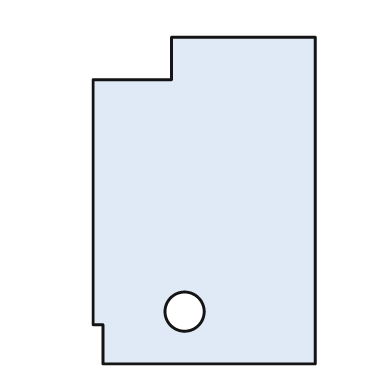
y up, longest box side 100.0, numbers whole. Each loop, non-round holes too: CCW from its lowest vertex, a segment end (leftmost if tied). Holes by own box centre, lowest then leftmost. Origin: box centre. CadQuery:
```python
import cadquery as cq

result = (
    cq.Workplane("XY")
    .moveTo(-31.0, -50.0)
    .lineTo(34.0, -50.0)
    .lineTo(34.0, 50.0)
    .lineTo(-10.0, 50.0)
    .lineTo(-10.0, 37.0)
    .lineTo(-34.0, 37.0)
    .lineTo(-34.0, -38.0)
    .lineTo(-31.0, -38.0)
    .close()
    .moveTo(-6.0, -34.0)
    .circle(6.0)
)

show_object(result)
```